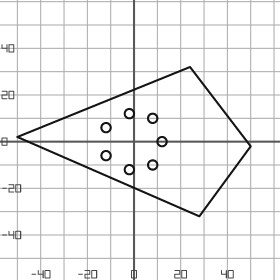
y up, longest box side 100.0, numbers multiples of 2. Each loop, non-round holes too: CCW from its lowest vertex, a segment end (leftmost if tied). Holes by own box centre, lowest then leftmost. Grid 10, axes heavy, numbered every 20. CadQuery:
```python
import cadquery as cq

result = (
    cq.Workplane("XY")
    .moveTo(28.0, -32.0)
    .lineTo(50.0, -2.0)
    .lineTo(24.0, 32.0)
    .lineTo(-50.0, 2.0)
    .close()
    .moveTo(-2.0, -12.0)
    .circle(2.0)
    .moveTo(8.0, -10.0)
    .circle(2.0)
    .moveTo(-12.0, -6.0)
    .circle(2.0)
    .moveTo(12.0, 0.0)
    .circle(2.0)
    .moveTo(-12.0, 6.0)
    .circle(2.0)
    .moveTo(8.0, 10.0)
    .circle(2.0)
    .moveTo(-2.0, 12.0)
    .circle(2.0)
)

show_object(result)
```